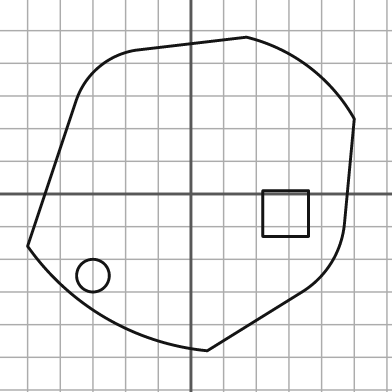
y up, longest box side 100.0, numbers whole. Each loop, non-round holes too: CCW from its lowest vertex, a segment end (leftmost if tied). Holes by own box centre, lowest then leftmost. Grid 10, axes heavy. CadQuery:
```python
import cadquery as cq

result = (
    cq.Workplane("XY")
    .moveTo(5.0, -48.0)
    .lineTo(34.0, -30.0)
    .threePointArc((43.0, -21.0), (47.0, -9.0))
    .lineTo(50.0, 23.0)
    .threePointArc((36.0, 39.0), (17.0, 48.0))
    .lineTo(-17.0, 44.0)
    .threePointArc((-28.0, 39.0), (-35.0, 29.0))
    .lineTo(-50.0, -16.0)
    .threePointArc((-26.0, -38.0), (5.0, -48.0))
    .close()
    .moveTo(-30.0, -25.0)
    .circle(5.0)
    .moveTo(22.0, -13.0)
    .lineTo(36.0, -13.0)
    .lineTo(36.0, 1.0)
    .lineTo(22.0, 1.0)
    .close()
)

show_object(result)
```